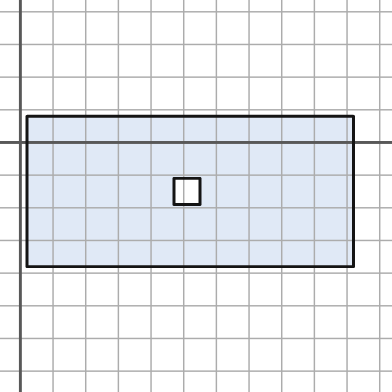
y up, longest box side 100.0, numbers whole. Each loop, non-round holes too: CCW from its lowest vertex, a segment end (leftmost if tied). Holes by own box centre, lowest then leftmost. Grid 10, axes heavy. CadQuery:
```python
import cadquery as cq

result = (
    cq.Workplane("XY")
    .moveTo(2.0, -38.0)
    .lineTo(102.0, -38.0)
    .lineTo(102.0, 8.0)
    .lineTo(2.0, 8.0)
    .close()
    .moveTo(47.0, -19.0)
    .lineTo(55.0, -19.0)
    .lineTo(55.0, -11.0)
    .lineTo(47.0, -11.0)
    .close()
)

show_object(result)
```